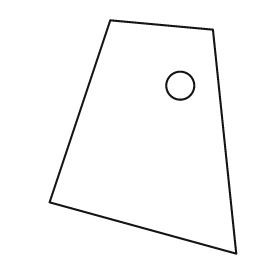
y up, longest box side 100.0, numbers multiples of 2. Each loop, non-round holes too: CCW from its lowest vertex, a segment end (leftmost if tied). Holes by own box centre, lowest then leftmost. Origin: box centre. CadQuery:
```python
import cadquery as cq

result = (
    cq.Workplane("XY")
    .moveTo(40.0, -50.0)
    .lineTo(30.0, 46.0)
    .lineTo(-14.0, 50.0)
    .lineTo(-40.0, -28.0)
    .close()
    .moveTo(16.0, 22.0)
    .circle(6.0)
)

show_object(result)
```